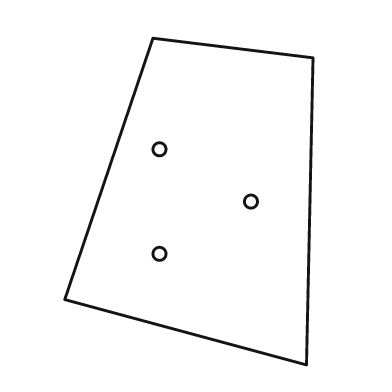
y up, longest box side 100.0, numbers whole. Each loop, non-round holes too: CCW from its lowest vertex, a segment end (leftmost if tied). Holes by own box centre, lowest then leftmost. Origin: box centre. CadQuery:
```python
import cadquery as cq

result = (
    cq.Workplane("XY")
    .moveTo(36.0, -50.0)
    .lineTo(38.0, 44.0)
    .lineTo(-11.0, 50.0)
    .lineTo(-38.0, -30.0)
    .close()
    .moveTo(-9.0, -16.0)
    .circle(2.0)
    .moveTo(19.0, 0.0)
    .circle(2.0)
    .moveTo(-9.0, 16.0)
    .circle(2.0)
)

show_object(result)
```